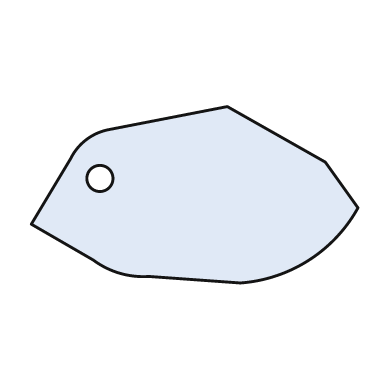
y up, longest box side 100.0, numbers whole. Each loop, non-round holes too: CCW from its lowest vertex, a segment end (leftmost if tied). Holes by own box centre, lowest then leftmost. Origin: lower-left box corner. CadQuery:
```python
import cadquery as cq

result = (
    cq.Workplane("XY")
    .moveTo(64.0, 0.0)
    .threePointArc((85.0, 7.0), (100.0, 23.0))
    .lineTo(90.0, 37.0)
    .lineTo(60.0, 54.0)
    .lineTo(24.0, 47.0)
    .threePointArc((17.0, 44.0), (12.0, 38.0))
    .lineTo(0.0, 18.0)
    .lineTo(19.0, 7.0)
    .threePointArc((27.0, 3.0), (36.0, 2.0))
    .close()
    .moveTo(21.0, 32.0)
    .circle(4.0)
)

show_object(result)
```